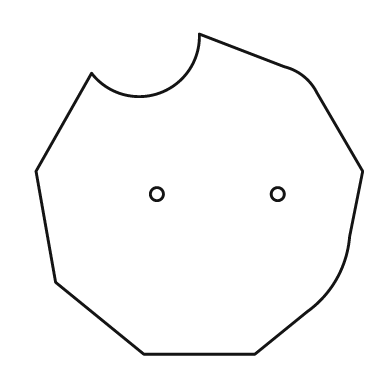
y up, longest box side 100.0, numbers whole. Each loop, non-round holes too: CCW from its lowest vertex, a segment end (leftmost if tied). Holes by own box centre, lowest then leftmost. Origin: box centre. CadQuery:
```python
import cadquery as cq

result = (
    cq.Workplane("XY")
    .moveTo(-17.0, -49.0)
    .lineTo(17.0, -49.0)
    .lineTo(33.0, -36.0)
    .threePointArc((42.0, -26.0), (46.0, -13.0))
    .lineTo(50.0, 7.0)
    .lineTo(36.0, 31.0)
    .threePointArc((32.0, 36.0), (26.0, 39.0))
    .lineTo(0.0, 49.0)
    .threePointArc((-12.0, 31.0), (-33.0, 37.0))
    .lineTo(-50.0, 7.0)
    .lineTo(-44.0, -27.0)
    .close()
    .moveTo(-13.0, 0.0)
    .circle(2.0)
    .moveTo(24.0, 0.0)
    .circle(2.0)
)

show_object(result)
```